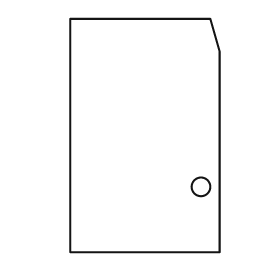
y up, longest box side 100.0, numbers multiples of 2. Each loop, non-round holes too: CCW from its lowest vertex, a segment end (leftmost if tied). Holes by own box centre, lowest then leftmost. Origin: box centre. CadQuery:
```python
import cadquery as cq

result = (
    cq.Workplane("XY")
    .moveTo(-32.0, -50.0)
    .lineTo(32.0, -50.0)
    .lineTo(32.0, 36.0)
    .lineTo(28.0, 50.0)
    .lineTo(-32.0, 50.0)
    .close()
    .moveTo(24.0, -22.0)
    .circle(4.0)
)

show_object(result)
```